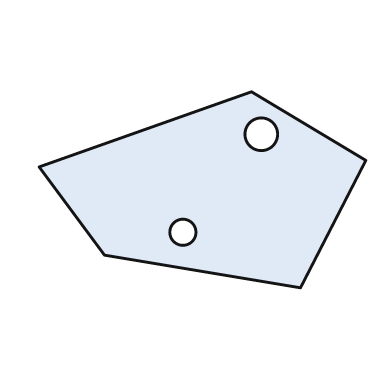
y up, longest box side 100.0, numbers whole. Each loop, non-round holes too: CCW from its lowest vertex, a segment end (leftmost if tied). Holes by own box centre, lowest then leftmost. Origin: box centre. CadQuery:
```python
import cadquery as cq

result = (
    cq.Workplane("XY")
    .moveTo(30.0, -30.0)
    .lineTo(50.0, 9.0)
    .lineTo(15.0, 30.0)
    .lineTo(-50.0, 7.0)
    .lineTo(-30.0, -20.0)
    .close()
    .moveTo(-6.0, -13.0)
    .circle(4.0)
    .moveTo(18.0, 17.0)
    .circle(5.0)
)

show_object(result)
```